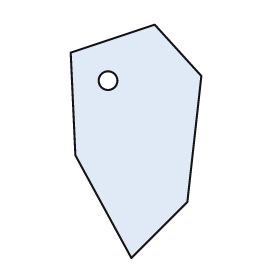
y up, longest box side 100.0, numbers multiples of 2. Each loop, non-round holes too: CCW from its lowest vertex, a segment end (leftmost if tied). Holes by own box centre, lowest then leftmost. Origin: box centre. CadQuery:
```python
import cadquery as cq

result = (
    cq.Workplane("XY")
    .moveTo(-2.0, -50.0)
    .lineTo(22.0, -26.0)
    .lineTo(28.0, 28.0)
    .lineTo(8.0, 50.0)
    .lineTo(-28.0, 38.0)
    .lineTo(-26.0, -6.0)
    .close()
    .moveTo(-12.0, 26.0)
    .circle(4.0)
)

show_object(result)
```